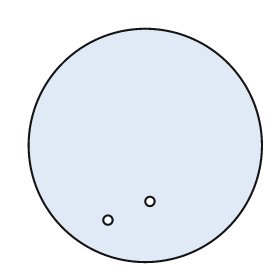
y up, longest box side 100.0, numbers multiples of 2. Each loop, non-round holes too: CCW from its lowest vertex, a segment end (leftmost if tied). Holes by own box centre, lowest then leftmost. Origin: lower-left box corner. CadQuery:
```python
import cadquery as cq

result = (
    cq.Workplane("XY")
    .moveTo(50.0, 50.0)
    .circle(50.0)
    .moveTo(34.0, 18.0)
    .circle(2.0)
    .moveTo(52.0, 26.0)
    .circle(2.0)
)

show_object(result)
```